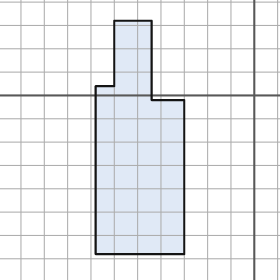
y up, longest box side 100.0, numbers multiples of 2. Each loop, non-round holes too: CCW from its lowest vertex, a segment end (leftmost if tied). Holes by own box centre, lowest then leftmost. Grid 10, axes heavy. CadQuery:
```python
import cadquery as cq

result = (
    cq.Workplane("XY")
    .moveTo(-68.0, -68.0)
    .lineTo(-30.0, -68.0)
    .lineTo(-30.0, -2.0)
    .lineTo(-44.0, -2.0)
    .lineTo(-44.0, 32.0)
    .lineTo(-60.0, 32.0)
    .lineTo(-60.0, 4.0)
    .lineTo(-68.0, 4.0)
    .close()
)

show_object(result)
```